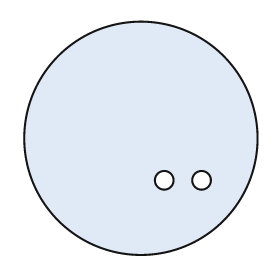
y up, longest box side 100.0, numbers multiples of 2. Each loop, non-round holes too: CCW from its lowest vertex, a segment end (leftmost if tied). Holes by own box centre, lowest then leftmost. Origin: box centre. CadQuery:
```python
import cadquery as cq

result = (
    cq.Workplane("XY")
    .moveTo(0.0, 0.0)
    .circle(50.0)
    .moveTo(10.0, -18.0)
    .circle(4.0)
    .moveTo(26.0, -18.0)
    .circle(4.0)
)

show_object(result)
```